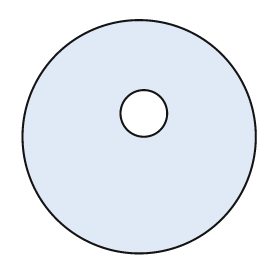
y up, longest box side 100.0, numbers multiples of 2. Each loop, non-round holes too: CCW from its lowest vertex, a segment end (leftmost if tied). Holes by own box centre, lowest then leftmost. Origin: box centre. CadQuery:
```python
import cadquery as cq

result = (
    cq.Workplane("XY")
    .moveTo(0.0, 0.0)
    .circle(50.0)
    .moveTo(2.0, 10.0)
    .circle(10.0)
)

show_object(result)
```